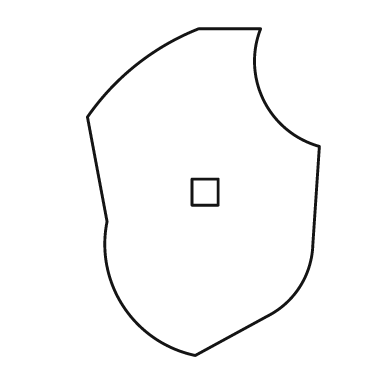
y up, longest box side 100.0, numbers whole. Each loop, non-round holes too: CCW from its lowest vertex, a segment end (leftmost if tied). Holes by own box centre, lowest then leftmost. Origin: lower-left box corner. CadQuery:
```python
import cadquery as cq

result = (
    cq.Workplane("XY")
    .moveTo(33.0, 0.0)
    .lineTo(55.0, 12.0)
    .threePointArc((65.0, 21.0), (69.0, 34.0))
    .lineTo(71.0, 64.0)
    .threePointArc((54.0, 78.0), (53.0, 100.0))
    .lineTo(34.0, 100.0)
    .threePointArc((15.0, 89.0), (0.0, 73.0))
    .lineTo(6.0, 41.0)
    .threePointArc((11.0, 15.0), (33.0, 0.0))
    .close()
    .moveTo(32.0, 46.0)
    .lineTo(40.0, 46.0)
    .lineTo(40.0, 54.0)
    .lineTo(32.0, 54.0)
    .close()
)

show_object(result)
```